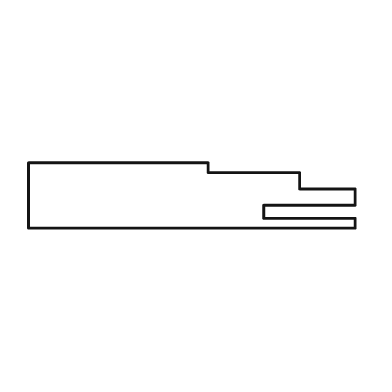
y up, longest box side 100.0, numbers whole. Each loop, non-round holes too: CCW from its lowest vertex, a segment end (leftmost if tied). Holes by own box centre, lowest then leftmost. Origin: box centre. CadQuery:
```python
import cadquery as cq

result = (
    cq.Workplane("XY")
    .moveTo(-50.0, -10.0)
    .lineTo(50.0, -10.0)
    .lineTo(50.0, -7.0)
    .lineTo(22.0, -7.0)
    .lineTo(22.0, -3.0)
    .lineTo(50.0, -3.0)
    .lineTo(50.0, 2.0)
    .lineTo(33.0, 2.0)
    .lineTo(33.0, 7.0)
    .lineTo(5.0, 7.0)
    .lineTo(5.0, 10.0)
    .lineTo(-50.0, 10.0)
    .close()
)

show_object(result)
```